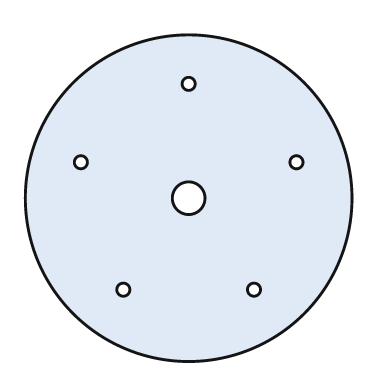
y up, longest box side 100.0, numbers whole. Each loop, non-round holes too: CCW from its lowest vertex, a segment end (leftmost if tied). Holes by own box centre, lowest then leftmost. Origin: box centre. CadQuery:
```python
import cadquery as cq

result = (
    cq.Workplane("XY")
    .moveTo(0.0, 0.0)
    .circle(50.0)
    .moveTo(-20.0, -28.0)
    .circle(2.0)
    .moveTo(20.0, -28.0)
    .circle(2.0)
    .moveTo(0.0, 0.0)
    .circle(5.0)
    .moveTo(-33.0, 11.0)
    .circle(2.0)
    .moveTo(33.0, 11.0)
    .circle(2.0)
    .moveTo(0.0, 35.0)
    .circle(2.0)
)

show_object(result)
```